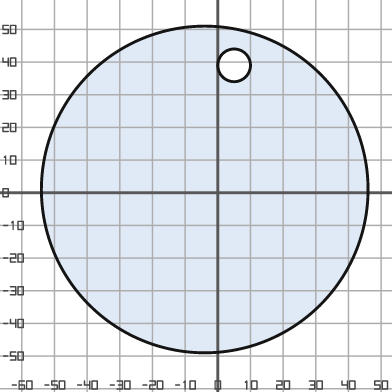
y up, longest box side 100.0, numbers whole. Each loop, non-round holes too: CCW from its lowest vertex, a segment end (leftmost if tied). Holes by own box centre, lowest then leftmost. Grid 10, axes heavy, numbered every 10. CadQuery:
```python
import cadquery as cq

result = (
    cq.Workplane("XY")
    .moveTo(-4.0, 1.0)
    .circle(50.0)
    .moveTo(5.0, 39.0)
    .circle(5.0)
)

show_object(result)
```